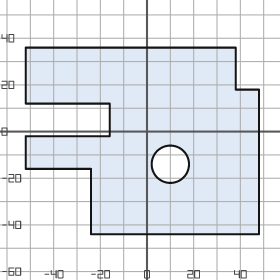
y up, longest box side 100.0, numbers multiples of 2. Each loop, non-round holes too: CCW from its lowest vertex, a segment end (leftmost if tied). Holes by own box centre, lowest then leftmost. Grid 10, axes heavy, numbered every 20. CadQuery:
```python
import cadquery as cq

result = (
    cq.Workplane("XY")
    .moveTo(-24.0, -44.0)
    .lineTo(48.0, -44.0)
    .lineTo(48.0, 18.0)
    .lineTo(38.0, 18.0)
    .lineTo(38.0, 36.0)
    .lineTo(-52.0, 36.0)
    .lineTo(-52.0, 12.0)
    .lineTo(-16.0, 12.0)
    .lineTo(-16.0, -2.0)
    .lineTo(-52.0, -2.0)
    .lineTo(-52.0, -16.0)
    .lineTo(-24.0, -16.0)
    .close()
    .moveTo(10.0, -14.0)
    .circle(8.0)
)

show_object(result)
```